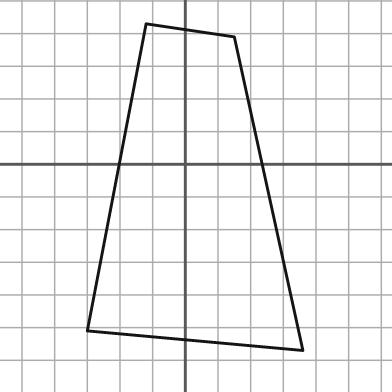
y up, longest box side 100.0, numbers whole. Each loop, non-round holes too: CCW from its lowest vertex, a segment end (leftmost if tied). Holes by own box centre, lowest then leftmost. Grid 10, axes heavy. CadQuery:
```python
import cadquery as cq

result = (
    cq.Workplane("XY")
    .moveTo(36.0, -57.0)
    .lineTo(15.0, 39.0)
    .lineTo(-12.0, 43.0)
    .lineTo(-30.0, -51.0)
    .close()
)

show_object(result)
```